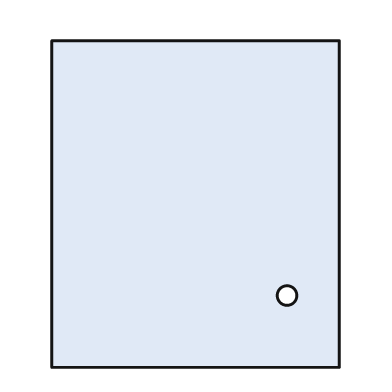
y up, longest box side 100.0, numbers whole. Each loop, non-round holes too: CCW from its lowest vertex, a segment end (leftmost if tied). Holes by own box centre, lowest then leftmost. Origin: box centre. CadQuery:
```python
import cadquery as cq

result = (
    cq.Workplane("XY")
    .moveTo(-44.0, -50.0)
    .lineTo(44.0, -50.0)
    .lineTo(44.0, 50.0)
    .lineTo(-44.0, 50.0)
    .close()
    .moveTo(28.0, -28.0)
    .circle(3.0)
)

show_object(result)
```